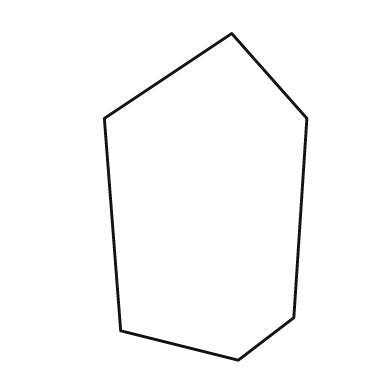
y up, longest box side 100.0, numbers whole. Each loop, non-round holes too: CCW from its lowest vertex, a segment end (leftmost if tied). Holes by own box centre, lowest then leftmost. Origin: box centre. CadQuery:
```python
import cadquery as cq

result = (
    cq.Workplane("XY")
    .moveTo(10.0, -50.0)
    .lineTo(27.0, -37.0)
    .lineTo(31.0, 24.0)
    .lineTo(8.0, 50.0)
    .lineTo(-31.0, 24.0)
    .lineTo(-26.0, -41.0)
    .close()
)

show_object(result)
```